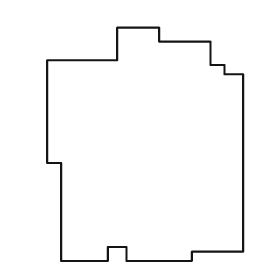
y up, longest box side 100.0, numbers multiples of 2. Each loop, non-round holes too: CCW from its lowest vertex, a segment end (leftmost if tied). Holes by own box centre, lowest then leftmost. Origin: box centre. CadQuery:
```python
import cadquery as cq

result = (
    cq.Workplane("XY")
    .moveTo(-36.0, -50.0)
    .lineTo(-16.0, -50.0)
    .lineTo(-16.0, -44.0)
    .lineTo(-8.0, -44.0)
    .lineTo(-8.0, -50.0)
    .lineTo(20.0, -50.0)
    .lineTo(20.0, -46.0)
    .lineTo(42.0, -46.0)
    .lineTo(42.0, 30.0)
    .lineTo(34.0, 30.0)
    .lineTo(34.0, 34.0)
    .lineTo(28.0, 34.0)
    .lineTo(28.0, 44.0)
    .lineTo(6.0, 44.0)
    .lineTo(6.0, 50.0)
    .lineTo(-12.0, 50.0)
    .lineTo(-12.0, 36.0)
    .lineTo(-42.0, 36.0)
    .lineTo(-42.0, -8.0)
    .lineTo(-36.0, -8.0)
    .close()
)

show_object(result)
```